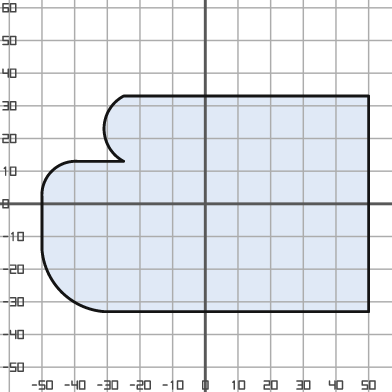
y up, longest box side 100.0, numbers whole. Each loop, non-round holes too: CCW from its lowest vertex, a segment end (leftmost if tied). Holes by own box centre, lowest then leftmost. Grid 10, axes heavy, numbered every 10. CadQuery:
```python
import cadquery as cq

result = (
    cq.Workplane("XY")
    .moveTo(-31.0, -33.0)
    .lineTo(50.0, -33.0)
    .lineTo(50.0, 33.0)
    .lineTo(-25.0, 33.0)
    .threePointArc((-31.0, 23.0), (-25.0, 13.0))
    .lineTo(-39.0, 13.0)
    .threePointArc((-47.0, 10.0), (-50.0, 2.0))
    .lineTo(-50.0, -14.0)
    .threePointArc((-44.0, -27.0), (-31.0, -33.0))
    .close()
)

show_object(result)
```